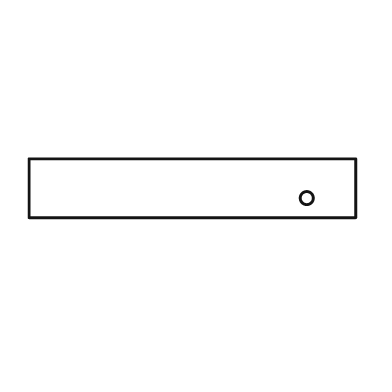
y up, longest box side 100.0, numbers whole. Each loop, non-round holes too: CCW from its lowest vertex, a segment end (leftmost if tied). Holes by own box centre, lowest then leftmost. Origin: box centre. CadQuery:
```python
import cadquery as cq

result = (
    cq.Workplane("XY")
    .moveTo(-50.0, -9.0)
    .lineTo(50.0, -9.0)
    .lineTo(50.0, 9.0)
    .lineTo(-50.0, 9.0)
    .close()
    .moveTo(35.0, -3.0)
    .circle(2.0)
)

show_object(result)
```